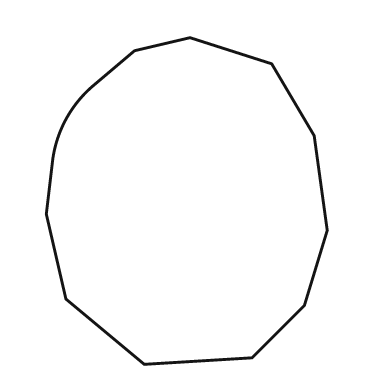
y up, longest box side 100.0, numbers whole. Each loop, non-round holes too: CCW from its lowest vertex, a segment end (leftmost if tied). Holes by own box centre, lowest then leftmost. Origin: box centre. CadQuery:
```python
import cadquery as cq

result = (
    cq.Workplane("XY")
    .moveTo(-13.0, -50.0)
    .lineTo(20.0, -48.0)
    .lineTo(36.0, -32.0)
    .lineTo(43.0, -9.0)
    .lineTo(39.0, 20.0)
    .lineTo(26.0, 42.0)
    .lineTo(1.0, 50.0)
    .lineTo(-16.0, 46.0)
    .lineTo(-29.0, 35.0)
    .threePointArc((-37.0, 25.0), (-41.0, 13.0))
    .lineTo(-43.0, -4.0)
    .lineTo(-37.0, -30.0)
    .close()
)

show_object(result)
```